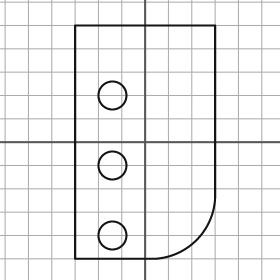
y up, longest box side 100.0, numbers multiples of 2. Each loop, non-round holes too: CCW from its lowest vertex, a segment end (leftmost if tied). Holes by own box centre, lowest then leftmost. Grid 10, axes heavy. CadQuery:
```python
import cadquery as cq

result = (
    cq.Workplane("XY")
    .moveTo(-30.0, -50.0)
    .lineTo(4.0, -50.0)
    .threePointArc((22.0, -42.0), (30.0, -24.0))
    .lineTo(30.0, 50.0)
    .lineTo(-30.0, 50.0)
    .close()
    .moveTo(-14.0, -40.0)
    .circle(6.0)
    .moveTo(-14.0, -10.0)
    .circle(6.0)
    .moveTo(-14.0, 20.0)
    .circle(6.0)
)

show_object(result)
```